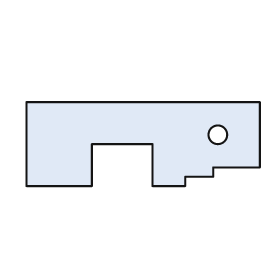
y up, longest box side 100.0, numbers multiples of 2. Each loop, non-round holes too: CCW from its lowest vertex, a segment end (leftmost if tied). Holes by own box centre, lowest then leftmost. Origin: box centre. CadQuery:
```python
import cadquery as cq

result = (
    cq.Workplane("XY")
    .moveTo(-50.0, -18.0)
    .lineTo(-22.0, -18.0)
    .lineTo(-22.0, 0.0)
    .lineTo(4.0, 0.0)
    .lineTo(4.0, -18.0)
    .lineTo(18.0, -18.0)
    .lineTo(18.0, -14.0)
    .lineTo(30.0, -14.0)
    .lineTo(30.0, -10.0)
    .lineTo(50.0, -10.0)
    .lineTo(50.0, 18.0)
    .lineTo(-50.0, 18.0)
    .close()
    .moveTo(32.0, 4.0)
    .circle(4.0)
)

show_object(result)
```